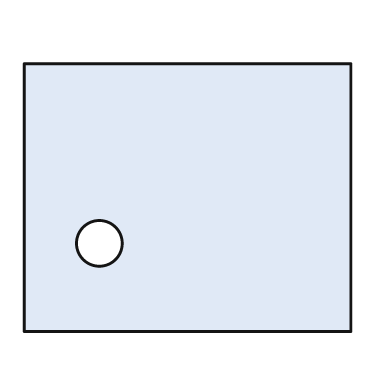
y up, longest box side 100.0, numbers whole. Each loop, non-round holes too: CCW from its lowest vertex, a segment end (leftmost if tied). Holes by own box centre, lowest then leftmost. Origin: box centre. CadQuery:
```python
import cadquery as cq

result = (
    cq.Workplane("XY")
    .moveTo(-50.0, -41.0)
    .lineTo(50.0, -41.0)
    .lineTo(50.0, 41.0)
    .lineTo(-50.0, 41.0)
    .close()
    .moveTo(-27.0, -14.0)
    .circle(7.0)
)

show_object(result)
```